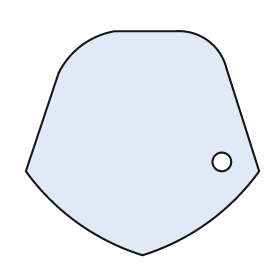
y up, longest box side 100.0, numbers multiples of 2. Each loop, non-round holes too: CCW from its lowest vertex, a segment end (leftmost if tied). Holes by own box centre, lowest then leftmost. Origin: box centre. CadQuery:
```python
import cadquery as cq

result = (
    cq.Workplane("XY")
    .moveTo(0.0, -48.0)
    .threePointArc((28.0, -34.0), (50.0, -12.0))
    .lineTo(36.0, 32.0)
    .threePointArc((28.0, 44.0), (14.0, 48.0))
    .lineTo(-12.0, 48.0)
    .threePointArc((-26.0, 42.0), (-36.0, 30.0))
    .lineTo(-50.0, -12.0)
    .threePointArc((-28.0, -34.0), (0.0, -48.0))
    .close()
    .moveTo(34.0, -8.0)
    .circle(4.0)
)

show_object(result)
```